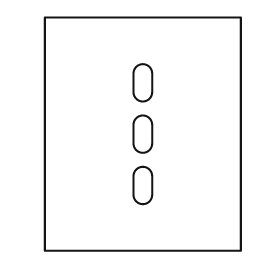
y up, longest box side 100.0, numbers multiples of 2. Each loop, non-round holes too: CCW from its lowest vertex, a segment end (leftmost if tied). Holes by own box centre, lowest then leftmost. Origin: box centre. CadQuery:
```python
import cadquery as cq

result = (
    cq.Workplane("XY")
    .moveTo(-42.0, -50.0)
    .lineTo(42.0, -50.0)
    .lineTo(42.0, 50.0)
    .lineTo(-42.0, 50.0)
    .close()
    .moveTo(-4.0, -26.0)
    .threePointArc((0.0, -30.0), (4.0, -26.0))
    .lineTo(4.0, -18.0)
    .threePointArc((0.0, -14.0), (-4.0, -18.0))
    .close()
    .moveTo(-4.0, -4.0)
    .threePointArc((0.0, -8.0), (4.0, -4.0))
    .lineTo(4.0, 4.0)
    .threePointArc((0.0, 8.0), (-4.0, 4.0))
    .close()
    .moveTo(-4.0, 18.0)
    .threePointArc((0.0, 14.0), (4.0, 18.0))
    .lineTo(4.0, 26.0)
    .threePointArc((0.0, 30.0), (-4.0, 26.0))
    .close()
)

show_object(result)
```